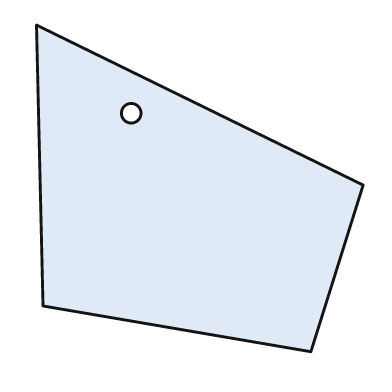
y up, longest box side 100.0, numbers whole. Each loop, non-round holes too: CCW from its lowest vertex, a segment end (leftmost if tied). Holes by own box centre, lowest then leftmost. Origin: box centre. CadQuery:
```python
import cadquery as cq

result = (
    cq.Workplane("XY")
    .moveTo(34.0, -50.0)
    .lineTo(50.0, 1.0)
    .lineTo(-50.0, 50.0)
    .lineTo(-48.0, -36.0)
    .close()
    .moveTo(-21.0, 23.0)
    .circle(3.0)
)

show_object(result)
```